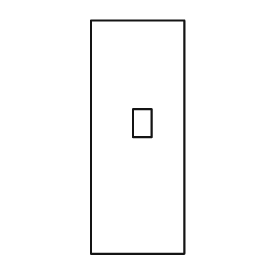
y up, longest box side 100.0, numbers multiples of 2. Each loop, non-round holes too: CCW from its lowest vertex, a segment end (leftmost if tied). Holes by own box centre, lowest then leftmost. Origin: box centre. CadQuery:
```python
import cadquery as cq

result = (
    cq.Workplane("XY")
    .moveTo(-20.0, -50.0)
    .lineTo(20.0, -50.0)
    .lineTo(20.0, 50.0)
    .lineTo(-20.0, 50.0)
    .close()
    .moveTo(-2.0, 0.0)
    .lineTo(6.0, 0.0)
    .lineTo(6.0, 12.0)
    .lineTo(-2.0, 12.0)
    .close()
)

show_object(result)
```